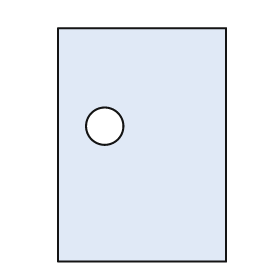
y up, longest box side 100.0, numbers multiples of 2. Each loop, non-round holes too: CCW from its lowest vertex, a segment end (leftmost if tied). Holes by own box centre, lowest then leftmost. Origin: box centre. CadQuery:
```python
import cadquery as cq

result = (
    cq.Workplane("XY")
    .moveTo(-36.0, -50.0)
    .lineTo(36.0, -50.0)
    .lineTo(36.0, 50.0)
    .lineTo(-36.0, 50.0)
    .close()
    .moveTo(-16.0, 8.0)
    .circle(8.0)
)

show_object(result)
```